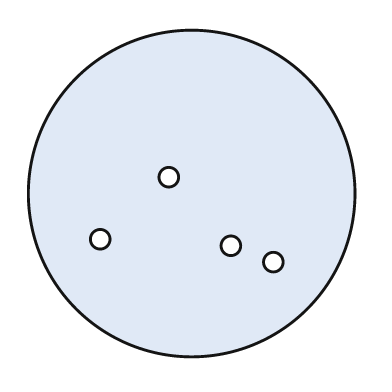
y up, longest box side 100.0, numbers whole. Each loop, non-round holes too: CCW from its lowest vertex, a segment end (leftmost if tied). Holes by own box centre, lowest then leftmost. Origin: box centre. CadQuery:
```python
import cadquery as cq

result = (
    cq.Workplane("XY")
    .moveTo(0.0, 0.0)
    .circle(50.0)
    .moveTo(25.0, -21.0)
    .circle(3.0)
    .moveTo(12.0, -16.0)
    .circle(3.0)
    .moveTo(-28.0, -14.0)
    .circle(3.0)
    .moveTo(-7.0, 5.0)
    .circle(3.0)
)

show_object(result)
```